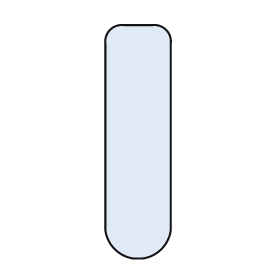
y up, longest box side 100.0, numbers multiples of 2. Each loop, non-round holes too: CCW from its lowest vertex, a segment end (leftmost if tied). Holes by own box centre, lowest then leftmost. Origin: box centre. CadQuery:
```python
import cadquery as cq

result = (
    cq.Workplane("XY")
    .moveTo(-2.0, -50.0)
    .lineTo(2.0, -50.0)
    .threePointArc((10.0, -46.0), (14.0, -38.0))
    .lineTo(14.0, 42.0)
    .threePointArc((12.0, 48.0), (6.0, 50.0))
    .lineTo(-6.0, 50.0)
    .threePointArc((-12.0, 48.0), (-14.0, 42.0))
    .lineTo(-14.0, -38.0)
    .threePointArc((-10.0, -46.0), (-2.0, -50.0))
    .close()
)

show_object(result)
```